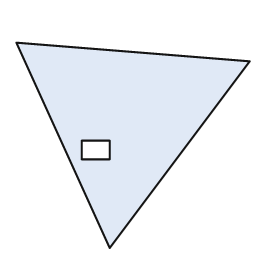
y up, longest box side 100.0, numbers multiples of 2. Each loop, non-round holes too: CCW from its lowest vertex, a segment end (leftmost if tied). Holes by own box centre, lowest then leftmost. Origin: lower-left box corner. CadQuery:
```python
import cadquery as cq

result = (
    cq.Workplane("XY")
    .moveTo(40.0, 0.0)
    .lineTo(100.0, 80.0)
    .lineTo(0.0, 88.0)
    .close()
    .moveTo(28.0, 38.0)
    .lineTo(40.0, 38.0)
    .lineTo(40.0, 46.0)
    .lineTo(28.0, 46.0)
    .close()
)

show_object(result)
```